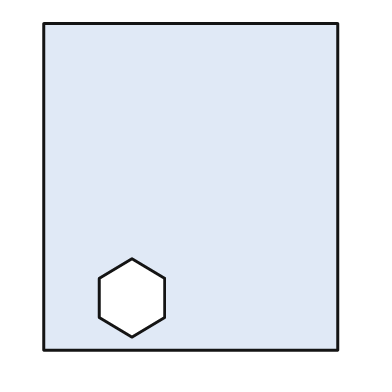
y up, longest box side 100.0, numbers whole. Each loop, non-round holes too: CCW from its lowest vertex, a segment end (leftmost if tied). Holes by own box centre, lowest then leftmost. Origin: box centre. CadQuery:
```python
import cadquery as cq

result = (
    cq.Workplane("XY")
    .moveTo(-45.0, -50.0)
    .lineTo(45.0, -50.0)
    .lineTo(45.0, 50.0)
    .lineTo(-45.0, 50.0)
    .close()
    .moveTo(-18.0, -46.0)
    .lineTo(-8.0, -40.0)
    .lineTo(-8.0, -28.0)
    .lineTo(-18.0, -22.0)
    .lineTo(-28.0, -28.0)
    .lineTo(-28.0, -40.0)
    .close()
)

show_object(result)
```